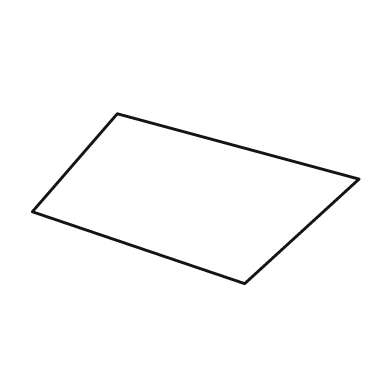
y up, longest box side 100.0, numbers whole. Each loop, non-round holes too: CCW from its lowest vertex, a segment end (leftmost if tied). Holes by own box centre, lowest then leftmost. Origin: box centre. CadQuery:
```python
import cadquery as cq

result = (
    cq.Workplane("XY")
    .moveTo(15.0, -26.0)
    .lineTo(50.0, 6.0)
    .lineTo(-24.0, 26.0)
    .lineTo(-50.0, -4.0)
    .close()
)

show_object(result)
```